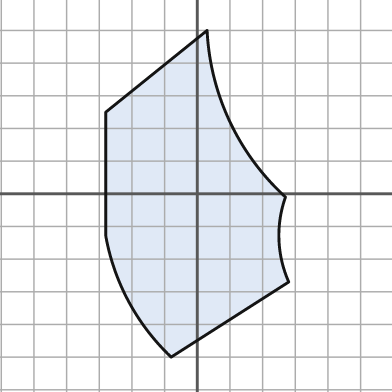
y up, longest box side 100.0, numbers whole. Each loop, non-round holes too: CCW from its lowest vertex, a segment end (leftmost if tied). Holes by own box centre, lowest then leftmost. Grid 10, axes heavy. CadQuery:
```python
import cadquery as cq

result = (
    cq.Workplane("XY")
    .moveTo(-8.0, -50.0)
    .lineTo(28.0, -27.0)
    .threePointArc((25.0, -14.0), (27.0, -1.0))
    .threePointArc((10.0, 22.0), (3.0, 50.0))
    .lineTo(-28.0, 25.0)
    .lineTo(-28.0, -13.0)
    .threePointArc((-21.0, -33.0), (-8.0, -50.0))
    .close()
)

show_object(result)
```